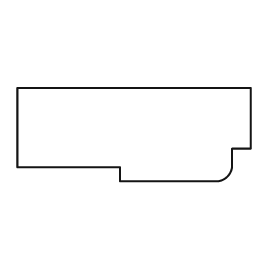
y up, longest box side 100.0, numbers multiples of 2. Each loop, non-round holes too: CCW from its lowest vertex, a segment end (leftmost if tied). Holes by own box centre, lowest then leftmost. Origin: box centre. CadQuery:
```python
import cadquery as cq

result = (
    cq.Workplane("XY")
    .moveTo(-6.0, -20.0)
    .lineTo(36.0, -20.0)
    .threePointArc((40.0, -18.0), (42.0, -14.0))
    .lineTo(42.0, -6.0)
    .lineTo(50.0, -6.0)
    .lineTo(50.0, 20.0)
    .lineTo(-50.0, 20.0)
    .lineTo(-50.0, -14.0)
    .lineTo(-6.0, -14.0)
    .close()
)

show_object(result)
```